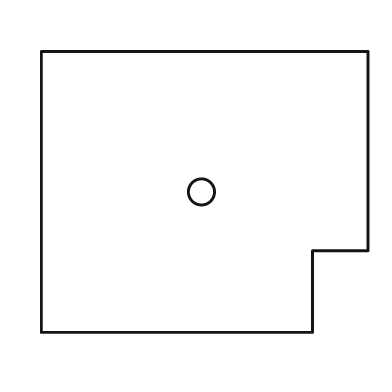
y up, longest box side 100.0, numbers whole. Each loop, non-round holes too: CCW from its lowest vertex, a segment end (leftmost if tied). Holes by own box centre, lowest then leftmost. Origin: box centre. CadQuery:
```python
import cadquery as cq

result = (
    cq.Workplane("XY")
    .moveTo(-50.0, -43.0)
    .lineTo(33.0, -43.0)
    .lineTo(33.0, -18.0)
    .lineTo(50.0, -18.0)
    .lineTo(50.0, 43.0)
    .lineTo(-50.0, 43.0)
    .close()
    .moveTo(-1.0, 0.0)
    .circle(4.0)
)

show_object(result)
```